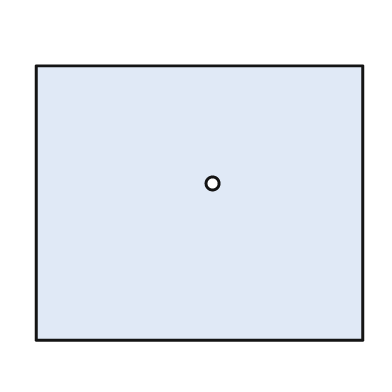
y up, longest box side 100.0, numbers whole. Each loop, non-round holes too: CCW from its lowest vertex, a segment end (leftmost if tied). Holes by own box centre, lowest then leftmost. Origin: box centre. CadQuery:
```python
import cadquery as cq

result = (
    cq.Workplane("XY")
    .moveTo(-50.0, -42.0)
    .lineTo(50.0, -42.0)
    .lineTo(50.0, 42.0)
    .lineTo(-50.0, 42.0)
    .close()
    .moveTo(4.0, 6.0)
    .circle(2.0)
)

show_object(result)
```